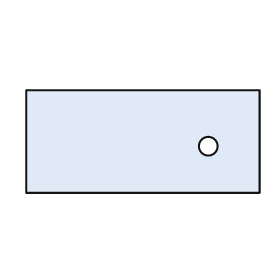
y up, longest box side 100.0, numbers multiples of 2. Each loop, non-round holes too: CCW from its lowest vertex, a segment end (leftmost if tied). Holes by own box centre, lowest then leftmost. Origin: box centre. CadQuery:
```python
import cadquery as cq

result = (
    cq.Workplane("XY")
    .moveTo(-50.0, -22.0)
    .lineTo(50.0, -22.0)
    .lineTo(50.0, 22.0)
    .lineTo(-50.0, 22.0)
    .close()
    .moveTo(28.0, -2.0)
    .circle(4.0)
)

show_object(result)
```